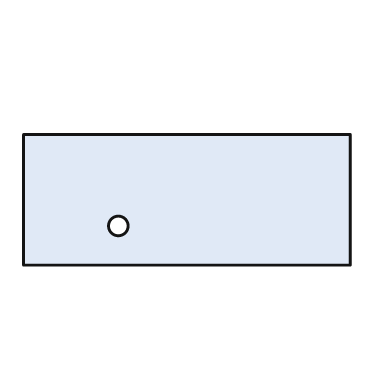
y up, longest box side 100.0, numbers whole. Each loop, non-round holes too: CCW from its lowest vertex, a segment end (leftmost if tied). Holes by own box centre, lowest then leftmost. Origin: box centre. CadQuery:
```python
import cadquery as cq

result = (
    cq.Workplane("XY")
    .moveTo(-50.0, -20.0)
    .lineTo(50.0, -20.0)
    .lineTo(50.0, 20.0)
    .lineTo(-50.0, 20.0)
    .close()
    .moveTo(-21.0, -8.0)
    .circle(3.0)
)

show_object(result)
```